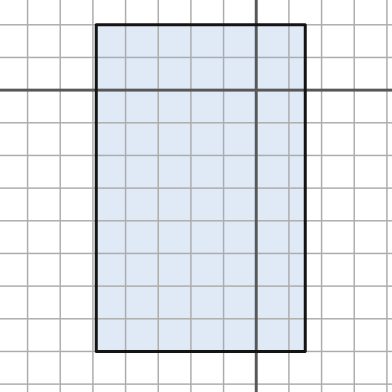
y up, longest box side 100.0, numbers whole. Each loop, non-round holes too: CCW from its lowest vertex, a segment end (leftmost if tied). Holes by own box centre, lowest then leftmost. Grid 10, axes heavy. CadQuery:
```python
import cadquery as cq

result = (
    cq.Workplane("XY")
    .moveTo(-49.0, -80.0)
    .lineTo(15.0, -80.0)
    .lineTo(15.0, 20.0)
    .lineTo(-49.0, 20.0)
    .close()
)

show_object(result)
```